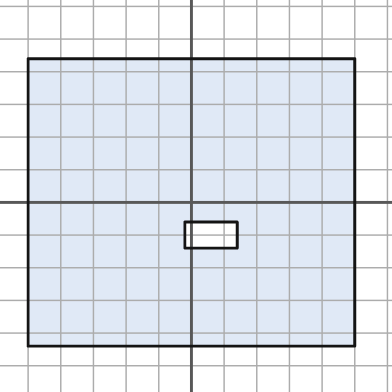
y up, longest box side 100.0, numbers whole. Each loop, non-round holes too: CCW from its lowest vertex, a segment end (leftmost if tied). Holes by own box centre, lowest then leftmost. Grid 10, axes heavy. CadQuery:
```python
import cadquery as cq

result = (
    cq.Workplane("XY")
    .moveTo(-50.0, -44.0)
    .lineTo(50.0, -44.0)
    .lineTo(50.0, 44.0)
    .lineTo(-50.0, 44.0)
    .close()
    .moveTo(-2.0, -14.0)
    .lineTo(14.0, -14.0)
    .lineTo(14.0, -6.0)
    .lineTo(-2.0, -6.0)
    .close()
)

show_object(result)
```